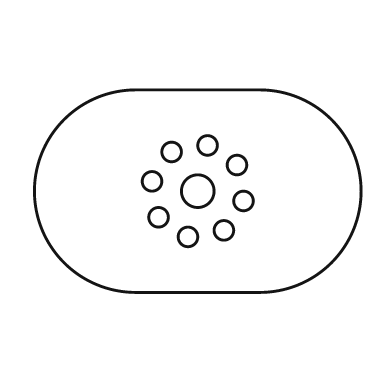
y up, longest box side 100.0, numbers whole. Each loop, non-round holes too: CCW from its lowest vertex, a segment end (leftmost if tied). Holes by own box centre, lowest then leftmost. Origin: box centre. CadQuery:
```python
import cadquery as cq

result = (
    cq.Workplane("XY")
    .moveTo(-19.0, -31.0)
    .lineTo(19.0, -31.0)
    .threePointArc((50.0, 0.0), (19.0, 31.0))
    .lineTo(-19.0, 31.0)
    .threePointArc((-50.0, 0.0), (-19.0, -31.0))
    .close()
    .moveTo(-3.0, -14.0)
    .circle(3.0)
    .moveTo(8.0, -12.0)
    .circle(3.0)
    .moveTo(-12.0, -8.0)
    .circle(3.0)
    .moveTo(14.0, -3.0)
    .circle(3.0)
    .moveTo(0.0, 0.0)
    .circle(5.0)
    .moveTo(-14.0, 3.0)
    .circle(3.0)
    .moveTo(12.0, 8.0)
    .circle(3.0)
    .moveTo(-8.0, 12.0)
    .circle(3.0)
    .moveTo(3.0, 14.0)
    .circle(3.0)
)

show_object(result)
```